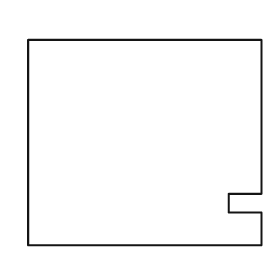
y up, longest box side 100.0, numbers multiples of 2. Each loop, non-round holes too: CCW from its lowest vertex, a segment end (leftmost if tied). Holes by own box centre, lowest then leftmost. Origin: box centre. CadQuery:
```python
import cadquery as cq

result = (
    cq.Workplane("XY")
    .moveTo(-50.0, -44.0)
    .lineTo(50.0, -44.0)
    .lineTo(50.0, -30.0)
    .lineTo(36.0, -30.0)
    .lineTo(36.0, -22.0)
    .lineTo(50.0, -22.0)
    .lineTo(50.0, 44.0)
    .lineTo(-50.0, 44.0)
    .close()
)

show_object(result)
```